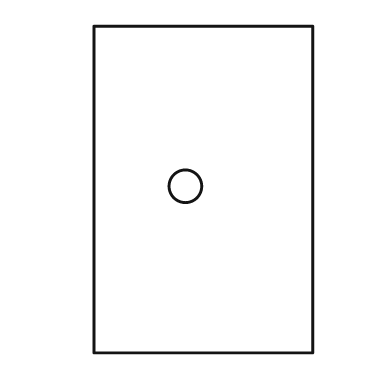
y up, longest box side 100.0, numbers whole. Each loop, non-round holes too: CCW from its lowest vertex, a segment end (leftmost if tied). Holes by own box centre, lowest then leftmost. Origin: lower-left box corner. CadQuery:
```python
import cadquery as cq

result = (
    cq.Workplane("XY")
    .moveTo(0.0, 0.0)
    .lineTo(67.0, 0.0)
    .lineTo(67.0, 100.0)
    .lineTo(0.0, 100.0)
    .close()
    .moveTo(28.0, 51.0)
    .circle(5.0)
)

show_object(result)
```